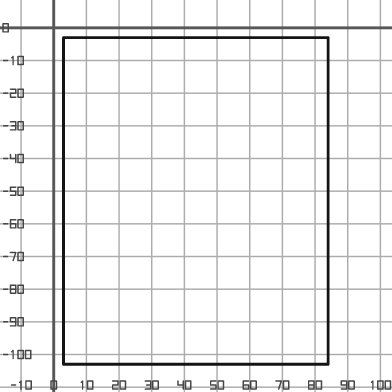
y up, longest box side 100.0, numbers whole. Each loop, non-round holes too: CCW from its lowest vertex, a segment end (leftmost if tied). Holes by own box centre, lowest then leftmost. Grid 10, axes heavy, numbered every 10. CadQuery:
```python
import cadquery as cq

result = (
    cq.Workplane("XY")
    .moveTo(3.0, -103.0)
    .lineTo(84.0, -103.0)
    .lineTo(84.0, -3.0)
    .lineTo(3.0, -3.0)
    .close()
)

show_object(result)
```